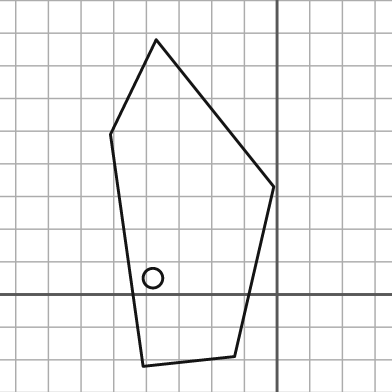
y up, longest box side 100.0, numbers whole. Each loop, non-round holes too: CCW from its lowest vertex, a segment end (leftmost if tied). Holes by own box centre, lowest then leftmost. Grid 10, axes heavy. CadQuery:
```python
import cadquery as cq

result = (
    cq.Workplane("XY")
    .moveTo(-41.0, -22.0)
    .lineTo(-13.0, -19.0)
    .lineTo(-1.0, 33.0)
    .lineTo(-37.0, 78.0)
    .lineTo(-51.0, 49.0)
    .close()
    .moveTo(-38.0, 5.0)
    .circle(3.0)
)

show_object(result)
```